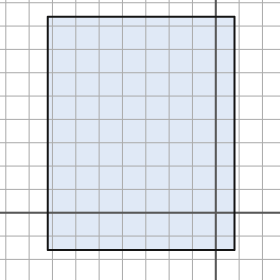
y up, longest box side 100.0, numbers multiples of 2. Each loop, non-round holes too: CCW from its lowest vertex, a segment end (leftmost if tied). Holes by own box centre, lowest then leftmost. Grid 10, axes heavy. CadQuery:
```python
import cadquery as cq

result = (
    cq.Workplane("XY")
    .moveTo(-72.0, -16.0)
    .lineTo(8.0, -16.0)
    .lineTo(8.0, 84.0)
    .lineTo(-72.0, 84.0)
    .close()
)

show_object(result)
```